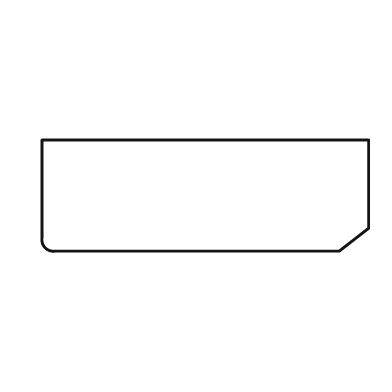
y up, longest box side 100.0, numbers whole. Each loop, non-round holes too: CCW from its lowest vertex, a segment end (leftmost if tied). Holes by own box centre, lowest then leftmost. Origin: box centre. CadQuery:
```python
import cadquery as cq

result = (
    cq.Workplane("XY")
    .moveTo(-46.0, -17.0)
    .lineTo(41.0, -17.0)
    .lineTo(50.0, -10.0)
    .lineTo(50.0, 17.0)
    .lineTo(-50.0, 17.0)
    .lineTo(-50.0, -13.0)
    .threePointArc((-49.0, -16.0), (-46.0, -17.0))
    .close()
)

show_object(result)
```